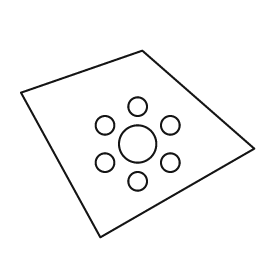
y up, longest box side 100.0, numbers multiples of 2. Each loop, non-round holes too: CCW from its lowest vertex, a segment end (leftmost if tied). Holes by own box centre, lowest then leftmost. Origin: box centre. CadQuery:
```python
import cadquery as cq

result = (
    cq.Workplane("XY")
    .moveTo(-16.0, -40.0)
    .lineTo(50.0, -2.0)
    .lineTo(2.0, 40.0)
    .lineTo(-50.0, 22.0)
    .close()
    .moveTo(0.0, -16.0)
    .circle(4.0)
    .moveTo(-14.0, -8.0)
    .circle(4.0)
    .moveTo(14.0, -8.0)
    .circle(4.0)
    .moveTo(0.0, 0.0)
    .circle(8.0)
    .moveTo(-14.0, 8.0)
    .circle(4.0)
    .moveTo(14.0, 8.0)
    .circle(4.0)
    .moveTo(0.0, 16.0)
    .circle(4.0)
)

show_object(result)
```